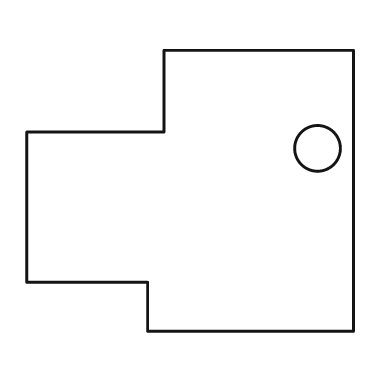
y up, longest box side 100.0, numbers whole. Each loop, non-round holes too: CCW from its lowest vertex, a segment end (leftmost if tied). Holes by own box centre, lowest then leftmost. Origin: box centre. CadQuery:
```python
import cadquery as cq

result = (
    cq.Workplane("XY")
    .moveTo(-13.0, -43.0)
    .lineTo(50.0, -43.0)
    .lineTo(50.0, 43.0)
    .lineTo(-8.0, 43.0)
    .lineTo(-8.0, 18.0)
    .lineTo(-50.0, 18.0)
    .lineTo(-50.0, -28.0)
    .lineTo(-13.0, -28.0)
    .close()
    .moveTo(39.0, 13.0)
    .circle(7.0)
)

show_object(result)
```